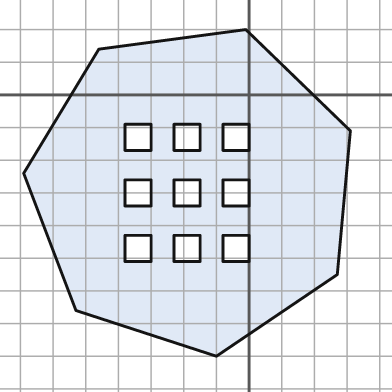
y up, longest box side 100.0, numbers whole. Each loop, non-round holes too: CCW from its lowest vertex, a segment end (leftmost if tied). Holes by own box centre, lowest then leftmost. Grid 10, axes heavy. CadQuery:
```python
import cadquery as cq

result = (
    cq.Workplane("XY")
    .moveTo(-10.0, -80.0)
    .lineTo(27.0, -55.0)
    .lineTo(31.0, -11.0)
    .lineTo(-1.0, 20.0)
    .lineTo(-46.0, 14.0)
    .lineTo(-69.0, -24.0)
    .lineTo(-53.0, -66.0)
    .close()
    .moveTo(-38.0, -51.0)
    .lineTo(-30.0, -51.0)
    .lineTo(-30.0, -43.0)
    .lineTo(-38.0, -43.0)
    .close()
    .moveTo(-23.0, -51.0)
    .lineTo(-15.0, -51.0)
    .lineTo(-15.0, -43.0)
    .lineTo(-23.0, -43.0)
    .close()
    .moveTo(-8.0, -51.0)
    .lineTo(0.0, -51.0)
    .lineTo(0.0, -43.0)
    .lineTo(-8.0, -43.0)
    .close()
    .moveTo(-38.0, -34.0)
    .lineTo(-30.0, -34.0)
    .lineTo(-30.0, -26.0)
    .lineTo(-38.0, -26.0)
    .close()
    .moveTo(-23.0, -34.0)
    .lineTo(-15.0, -34.0)
    .lineTo(-15.0, -26.0)
    .lineTo(-23.0, -26.0)
    .close()
    .moveTo(-8.0, -34.0)
    .lineTo(0.0, -34.0)
    .lineTo(0.0, -26.0)
    .lineTo(-8.0, -26.0)
    .close()
    .moveTo(-38.0, -17.0)
    .lineTo(-30.0, -17.0)
    .lineTo(-30.0, -9.0)
    .lineTo(-38.0, -9.0)
    .close()
    .moveTo(-23.0, -17.0)
    .lineTo(-15.0, -17.0)
    .lineTo(-15.0, -9.0)
    .lineTo(-23.0, -9.0)
    .close()
    .moveTo(-8.0, -17.0)
    .lineTo(0.0, -17.0)
    .lineTo(0.0, -9.0)
    .lineTo(-8.0, -9.0)
    .close()
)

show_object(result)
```